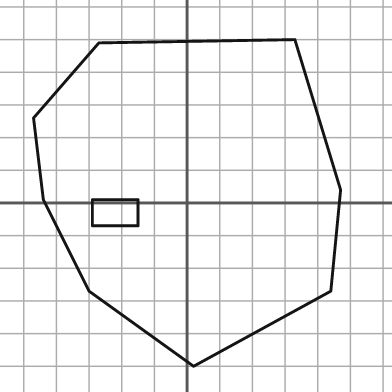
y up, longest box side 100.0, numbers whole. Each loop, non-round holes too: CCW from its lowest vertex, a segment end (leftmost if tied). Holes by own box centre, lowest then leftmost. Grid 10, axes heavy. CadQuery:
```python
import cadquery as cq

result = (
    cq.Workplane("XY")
    .moveTo(2.0, -50.0)
    .lineTo(44.0, -27.0)
    .lineTo(47.0, 4.0)
    .lineTo(33.0, 50.0)
    .lineTo(-27.0, 49.0)
    .lineTo(-47.0, 26.0)
    .lineTo(-44.0, 1.0)
    .lineTo(-30.0, -27.0)
    .close()
    .moveTo(-29.0, -7.0)
    .lineTo(-15.0, -7.0)
    .lineTo(-15.0, 1.0)
    .lineTo(-29.0, 1.0)
    .close()
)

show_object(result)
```